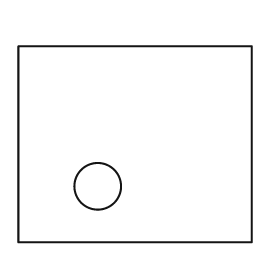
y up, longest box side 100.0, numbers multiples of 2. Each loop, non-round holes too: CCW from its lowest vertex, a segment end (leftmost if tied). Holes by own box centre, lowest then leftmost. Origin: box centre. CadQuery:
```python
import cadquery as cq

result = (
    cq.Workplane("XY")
    .moveTo(-50.0, -42.0)
    .lineTo(50.0, -42.0)
    .lineTo(50.0, 42.0)
    .lineTo(-50.0, 42.0)
    .close()
    .moveTo(-16.0, -18.0)
    .circle(10.0)
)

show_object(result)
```